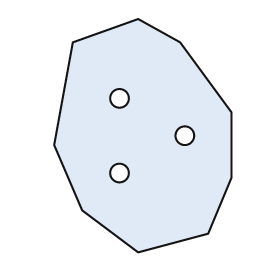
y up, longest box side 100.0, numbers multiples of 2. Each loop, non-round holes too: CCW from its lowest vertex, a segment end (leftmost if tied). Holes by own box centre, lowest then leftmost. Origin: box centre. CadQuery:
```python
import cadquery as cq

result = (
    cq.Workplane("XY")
    .moveTo(-2.0, -50.0)
    .lineTo(28.0, -42.0)
    .lineTo(38.0, -18.0)
    .lineTo(38.0, 10.0)
    .lineTo(16.0, 40.0)
    .lineTo(-2.0, 50.0)
    .lineTo(-30.0, 40.0)
    .lineTo(-38.0, -4.0)
    .lineTo(-26.0, -32.0)
    .close()
    .moveTo(-10.0, -16.0)
    .circle(4.0)
    .moveTo(18.0, 0.0)
    .circle(4.0)
    .moveTo(-10.0, 16.0)
    .circle(4.0)
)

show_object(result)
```